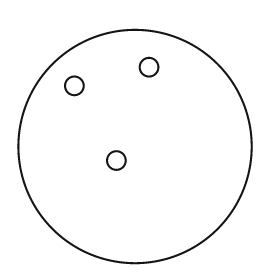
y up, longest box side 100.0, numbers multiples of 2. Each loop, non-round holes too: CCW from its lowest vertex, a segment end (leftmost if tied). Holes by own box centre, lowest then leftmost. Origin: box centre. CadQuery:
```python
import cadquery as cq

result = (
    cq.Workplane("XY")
    .moveTo(0.0, 0.0)
    .circle(50.0)
    .moveTo(-8.0, -6.0)
    .circle(4.0)
    .moveTo(-26.0, 26.0)
    .circle(4.0)
    .moveTo(6.0, 34.0)
    .circle(4.0)
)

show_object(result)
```